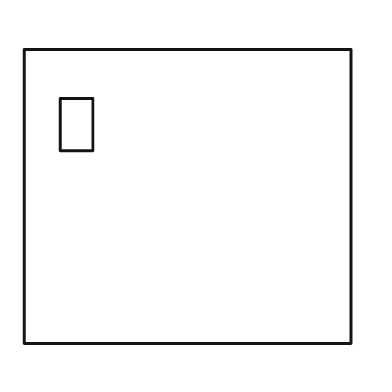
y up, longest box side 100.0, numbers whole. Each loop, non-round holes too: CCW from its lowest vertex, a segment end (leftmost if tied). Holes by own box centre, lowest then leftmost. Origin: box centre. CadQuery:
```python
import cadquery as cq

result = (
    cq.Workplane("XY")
    .moveTo(-50.0, -45.0)
    .lineTo(50.0, -45.0)
    .lineTo(50.0, 45.0)
    .lineTo(-50.0, 45.0)
    .close()
    .moveTo(-39.0, 14.0)
    .lineTo(-29.0, 14.0)
    .lineTo(-29.0, 30.0)
    .lineTo(-39.0, 30.0)
    .close()
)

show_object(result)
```